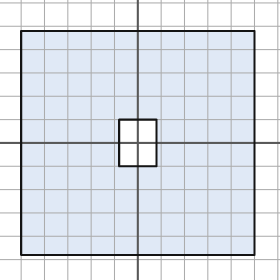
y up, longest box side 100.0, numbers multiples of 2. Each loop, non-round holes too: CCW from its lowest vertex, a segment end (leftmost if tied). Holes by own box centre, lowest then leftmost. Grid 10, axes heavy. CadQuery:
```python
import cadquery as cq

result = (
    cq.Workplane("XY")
    .moveTo(-50.0, -48.0)
    .lineTo(50.0, -48.0)
    .lineTo(50.0, 48.0)
    .lineTo(-50.0, 48.0)
    .close()
    .moveTo(-8.0, -10.0)
    .lineTo(8.0, -10.0)
    .lineTo(8.0, 10.0)
    .lineTo(-8.0, 10.0)
    .close()
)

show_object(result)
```